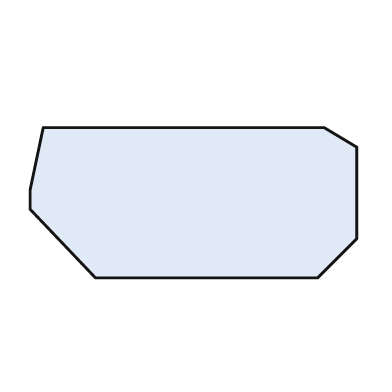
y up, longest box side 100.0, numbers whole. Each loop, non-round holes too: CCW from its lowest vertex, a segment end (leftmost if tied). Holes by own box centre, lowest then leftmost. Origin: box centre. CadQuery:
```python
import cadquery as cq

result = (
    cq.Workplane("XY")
    .moveTo(-30.0, -23.0)
    .lineTo(38.0, -23.0)
    .lineTo(50.0, -11.0)
    .lineTo(50.0, 17.0)
    .lineTo(40.0, 23.0)
    .lineTo(-46.0, 23.0)
    .lineTo(-50.0, 4.0)
    .lineTo(-50.0, -2.0)
    .close()
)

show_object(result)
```